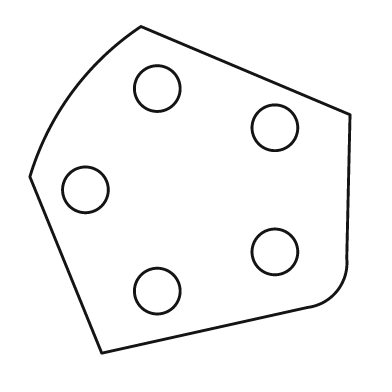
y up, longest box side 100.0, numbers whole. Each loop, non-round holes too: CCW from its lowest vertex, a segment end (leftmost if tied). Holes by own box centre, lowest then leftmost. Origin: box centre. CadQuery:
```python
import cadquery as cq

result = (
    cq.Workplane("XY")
    .moveTo(-27.0, -50.0)
    .lineTo(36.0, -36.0)
    .threePointArc((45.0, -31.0), (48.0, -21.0))
    .lineTo(49.0, 23.0)
    .lineTo(-15.0, 50.0)
    .threePointArc((-36.0, 30.0), (-49.0, 4.0))
    .close()
    .moveTo(-10.0, -31.0)
    .circle(7.0)
    .moveTo(26.0, -19.0)
    .circle(7.0)
    .moveTo(-32.0, 0.0)
    .circle(7.0)
    .moveTo(26.0, 19.0)
    .circle(7.0)
    .moveTo(-10.0, 31.0)
    .circle(7.0)
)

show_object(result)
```